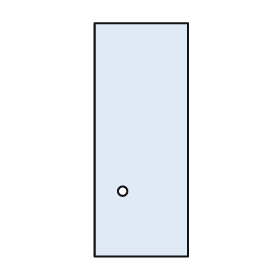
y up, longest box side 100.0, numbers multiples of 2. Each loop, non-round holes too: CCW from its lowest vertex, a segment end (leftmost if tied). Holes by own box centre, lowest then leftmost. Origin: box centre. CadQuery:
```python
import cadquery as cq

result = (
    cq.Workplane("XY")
    .moveTo(-20.0, -50.0)
    .lineTo(20.0, -50.0)
    .lineTo(20.0, 50.0)
    .lineTo(-20.0, 50.0)
    .close()
    .moveTo(-8.0, -22.0)
    .circle(2.0)
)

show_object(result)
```